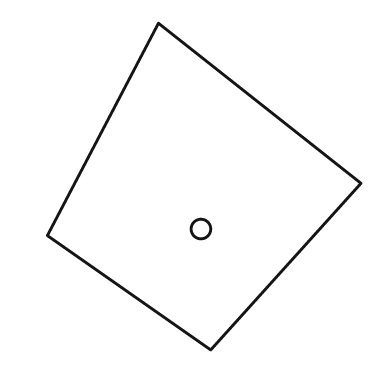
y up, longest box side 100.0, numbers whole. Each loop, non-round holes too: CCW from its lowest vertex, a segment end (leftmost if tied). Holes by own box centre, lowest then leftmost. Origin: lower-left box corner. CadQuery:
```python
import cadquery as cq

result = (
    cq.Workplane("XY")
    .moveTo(50.0, 0.0)
    .lineTo(96.0, 51.0)
    .lineTo(34.0, 100.0)
    .lineTo(0.0, 35.0)
    .close()
    .moveTo(47.0, 37.0)
    .circle(3.0)
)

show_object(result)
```